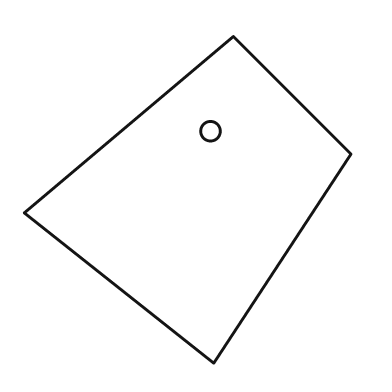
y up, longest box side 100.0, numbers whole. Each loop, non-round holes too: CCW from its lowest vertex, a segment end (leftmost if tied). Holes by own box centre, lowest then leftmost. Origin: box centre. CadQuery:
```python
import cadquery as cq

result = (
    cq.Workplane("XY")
    .moveTo(8.0, -50.0)
    .lineTo(50.0, 14.0)
    .lineTo(14.0, 50.0)
    .lineTo(-50.0, -4.0)
    .close()
    .moveTo(7.0, 21.0)
    .circle(3.0)
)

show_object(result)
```